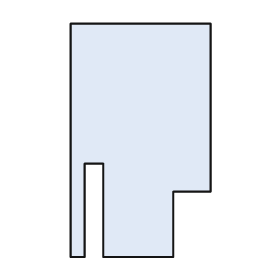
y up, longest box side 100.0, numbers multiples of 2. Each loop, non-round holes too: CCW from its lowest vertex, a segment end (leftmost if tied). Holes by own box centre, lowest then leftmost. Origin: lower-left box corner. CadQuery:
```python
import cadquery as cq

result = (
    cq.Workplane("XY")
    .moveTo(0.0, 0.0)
    .lineTo(6.0, 0.0)
    .lineTo(6.0, 40.0)
    .lineTo(14.0, 40.0)
    .lineTo(14.0, 0.0)
    .lineTo(44.0, 0.0)
    .lineTo(44.0, 28.0)
    .lineTo(60.0, 28.0)
    .lineTo(60.0, 100.0)
    .lineTo(0.0, 100.0)
    .close()
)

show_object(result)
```